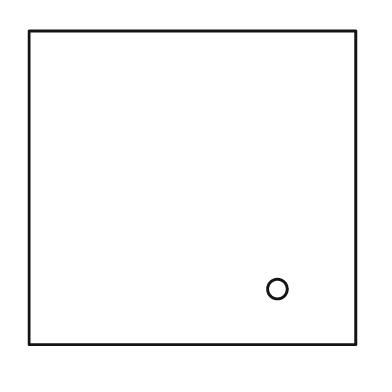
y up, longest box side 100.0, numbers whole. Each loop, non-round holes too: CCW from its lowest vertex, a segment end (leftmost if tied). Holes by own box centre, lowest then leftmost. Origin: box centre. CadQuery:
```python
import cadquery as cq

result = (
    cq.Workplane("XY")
    .moveTo(-50.0, -48.0)
    .lineTo(50.0, -48.0)
    .lineTo(50.0, 48.0)
    .lineTo(-50.0, 48.0)
    .close()
    .moveTo(26.0, -31.0)
    .circle(3.0)
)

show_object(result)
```